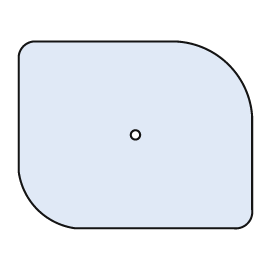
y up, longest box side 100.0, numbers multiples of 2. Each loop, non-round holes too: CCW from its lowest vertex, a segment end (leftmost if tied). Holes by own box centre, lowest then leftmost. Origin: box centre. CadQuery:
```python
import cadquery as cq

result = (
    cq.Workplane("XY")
    .moveTo(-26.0, -40.0)
    .lineTo(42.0, -40.0)
    .threePointArc((48.0, -38.0), (50.0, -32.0))
    .lineTo(50.0, 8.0)
    .threePointArc((40.0, 30.0), (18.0, 40.0))
    .lineTo(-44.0, 40.0)
    .threePointArc((-48.0, 38.0), (-50.0, 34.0))
    .lineTo(-50.0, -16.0)
    .threePointArc((-42.0, -32.0), (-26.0, -40.0))
    .close()
    .moveTo(0.0, 0.0)
    .circle(2.0)
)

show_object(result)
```